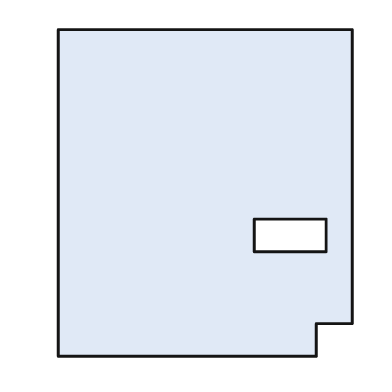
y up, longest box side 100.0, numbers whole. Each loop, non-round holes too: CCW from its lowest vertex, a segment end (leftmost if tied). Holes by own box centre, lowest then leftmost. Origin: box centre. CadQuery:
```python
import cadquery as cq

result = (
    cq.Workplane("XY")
    .moveTo(-45.0, -50.0)
    .lineTo(34.0, -50.0)
    .lineTo(34.0, -40.0)
    .lineTo(45.0, -40.0)
    .lineTo(45.0, 50.0)
    .lineTo(-45.0, 50.0)
    .close()
    .moveTo(15.0, -18.0)
    .lineTo(37.0, -18.0)
    .lineTo(37.0, -8.0)
    .lineTo(15.0, -8.0)
    .close()
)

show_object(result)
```